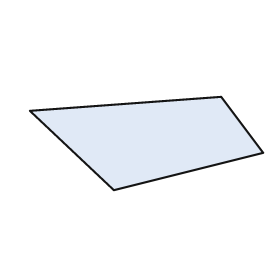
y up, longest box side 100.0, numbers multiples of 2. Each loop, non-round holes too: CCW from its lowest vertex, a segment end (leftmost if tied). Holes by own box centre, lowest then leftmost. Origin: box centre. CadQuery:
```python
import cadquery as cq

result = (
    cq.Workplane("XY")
    .moveTo(-14.0, -20.0)
    .lineTo(50.0, -4.0)
    .lineTo(32.0, 20.0)
    .lineTo(-50.0, 14.0)
    .close()
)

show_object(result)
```